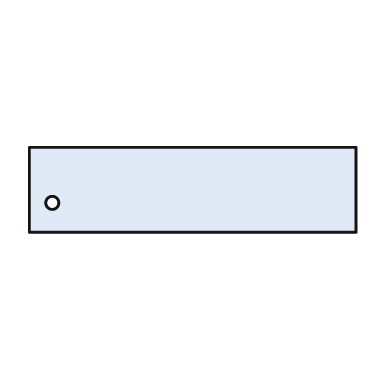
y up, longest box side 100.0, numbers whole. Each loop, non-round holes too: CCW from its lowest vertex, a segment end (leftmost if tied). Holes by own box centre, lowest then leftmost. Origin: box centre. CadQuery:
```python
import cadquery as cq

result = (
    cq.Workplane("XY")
    .moveTo(-50.0, -13.0)
    .lineTo(50.0, -13.0)
    .lineTo(50.0, 13.0)
    .lineTo(-50.0, 13.0)
    .close()
    .moveTo(-43.0, -4.0)
    .circle(2.0)
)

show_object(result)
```